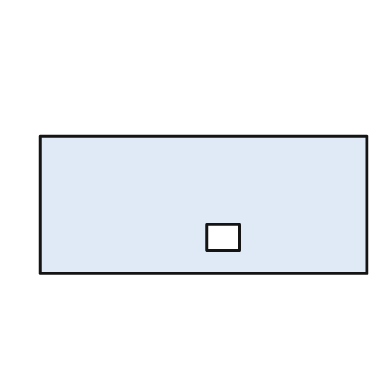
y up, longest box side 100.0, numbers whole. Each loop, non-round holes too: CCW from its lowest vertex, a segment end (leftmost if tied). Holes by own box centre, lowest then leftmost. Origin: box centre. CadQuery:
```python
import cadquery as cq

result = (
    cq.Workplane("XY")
    .moveTo(-50.0, -21.0)
    .lineTo(50.0, -21.0)
    .lineTo(50.0, 21.0)
    .lineTo(-50.0, 21.0)
    .close()
    .moveTo(1.0, -14.0)
    .lineTo(11.0, -14.0)
    .lineTo(11.0, -6.0)
    .lineTo(1.0, -6.0)
    .close()
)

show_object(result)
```